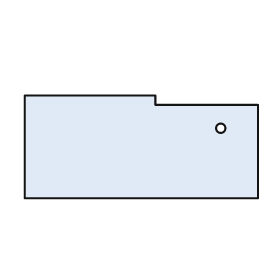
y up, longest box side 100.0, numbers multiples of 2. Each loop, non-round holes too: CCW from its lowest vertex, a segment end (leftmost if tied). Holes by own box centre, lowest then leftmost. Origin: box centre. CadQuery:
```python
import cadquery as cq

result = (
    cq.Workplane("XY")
    .moveTo(-50.0, -22.0)
    .lineTo(50.0, -22.0)
    .lineTo(50.0, 18.0)
    .lineTo(6.0, 18.0)
    .lineTo(6.0, 22.0)
    .lineTo(-50.0, 22.0)
    .close()
    .moveTo(34.0, 8.0)
    .circle(2.0)
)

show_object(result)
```